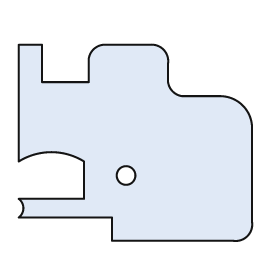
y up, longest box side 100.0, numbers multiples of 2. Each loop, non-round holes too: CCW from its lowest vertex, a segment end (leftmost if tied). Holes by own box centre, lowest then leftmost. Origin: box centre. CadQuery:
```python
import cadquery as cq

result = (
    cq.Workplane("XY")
    .moveTo(-10.0, -42.0)
    .lineTo(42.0, -42.0)
    .threePointArc((48.0, -40.0), (50.0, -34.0))
    .lineTo(50.0, 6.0)
    .threePointArc((46.0, 16.0), (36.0, 20.0))
    .lineTo(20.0, 20.0)
    .threePointArc((16.0, 22.0), (14.0, 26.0))
    .lineTo(14.0, 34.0)
    .threePointArc((12.0, 40.0), (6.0, 42.0))
    .lineTo(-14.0, 42.0)
    .threePointArc((-18.0, 40.0), (-20.0, 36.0))
    .lineTo(-20.0, 26.0)
    .lineTo(-40.0, 26.0)
    .lineTo(-40.0, 42.0)
    .lineTo(-50.0, 42.0)
    .lineTo(-50.0, -8.0)
    .threePointArc((-36.0, -4.0), (-22.0, -8.0))
    .lineTo(-22.0, -24.0)
    .lineTo(-50.0, -24.0)
    .threePointArc((-48.0, -28.0), (-50.0, -32.0))
    .lineTo(-10.0, -32.0)
    .close()
    .moveTo(-4.0, -14.0)
    .circle(4.0)
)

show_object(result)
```